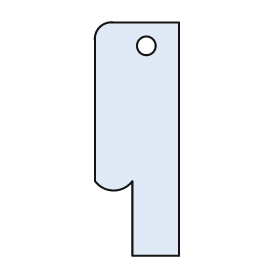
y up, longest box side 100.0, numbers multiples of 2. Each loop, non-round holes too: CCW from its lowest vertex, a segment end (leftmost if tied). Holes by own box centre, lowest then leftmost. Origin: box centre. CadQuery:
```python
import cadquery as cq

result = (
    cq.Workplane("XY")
    .moveTo(-2.0, -50.0)
    .lineTo(18.0, -50.0)
    .lineTo(18.0, 50.0)
    .lineTo(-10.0, 50.0)
    .threePointArc((-16.0, 48.0), (-18.0, 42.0))
    .lineTo(-18.0, -18.0)
    .threePointArc((-10.0, -22.0), (-2.0, -18.0))
    .close()
    .moveTo(4.0, 40.0)
    .circle(4.0)
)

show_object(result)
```